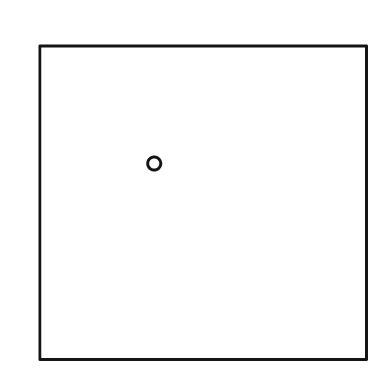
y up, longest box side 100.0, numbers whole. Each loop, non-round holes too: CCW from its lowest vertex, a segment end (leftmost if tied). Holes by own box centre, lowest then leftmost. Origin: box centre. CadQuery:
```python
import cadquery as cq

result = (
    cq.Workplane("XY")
    .moveTo(-50.0, -48.0)
    .lineTo(50.0, -48.0)
    .lineTo(50.0, 48.0)
    .lineTo(-50.0, 48.0)
    .close()
    .moveTo(-15.0, 12.0)
    .circle(2.0)
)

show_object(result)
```